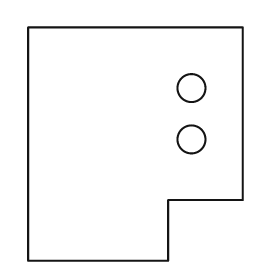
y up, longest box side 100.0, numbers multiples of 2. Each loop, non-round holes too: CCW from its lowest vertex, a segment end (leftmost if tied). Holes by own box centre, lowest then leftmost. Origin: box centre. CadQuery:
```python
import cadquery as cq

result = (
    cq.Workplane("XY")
    .moveTo(-46.0, -50.0)
    .lineTo(14.0, -50.0)
    .lineTo(14.0, -24.0)
    .lineTo(46.0, -24.0)
    .lineTo(46.0, 50.0)
    .lineTo(-46.0, 50.0)
    .close()
    .moveTo(24.0, 2.0)
    .circle(6.0)
    .moveTo(24.0, 24.0)
    .circle(6.0)
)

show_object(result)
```